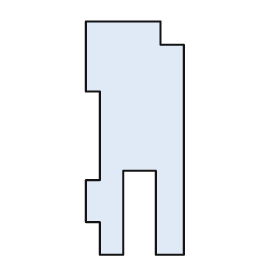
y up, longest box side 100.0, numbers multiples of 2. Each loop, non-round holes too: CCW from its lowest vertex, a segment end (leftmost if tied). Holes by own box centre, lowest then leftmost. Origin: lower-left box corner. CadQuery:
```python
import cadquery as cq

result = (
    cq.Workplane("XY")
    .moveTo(6.0, 0.0)
    .lineTo(16.0, 0.0)
    .lineTo(16.0, 36.0)
    .lineTo(30.0, 36.0)
    .lineTo(30.0, 0.0)
    .lineTo(42.0, 0.0)
    .lineTo(42.0, 90.0)
    .lineTo(32.0, 90.0)
    .lineTo(32.0, 100.0)
    .lineTo(0.0, 100.0)
    .lineTo(0.0, 70.0)
    .lineTo(6.0, 70.0)
    .lineTo(6.0, 32.0)
    .lineTo(0.0, 32.0)
    .lineTo(0.0, 14.0)
    .lineTo(6.0, 14.0)
    .close()
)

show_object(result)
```